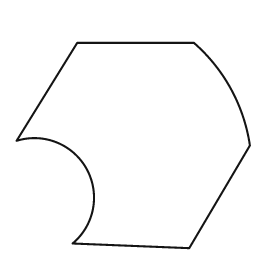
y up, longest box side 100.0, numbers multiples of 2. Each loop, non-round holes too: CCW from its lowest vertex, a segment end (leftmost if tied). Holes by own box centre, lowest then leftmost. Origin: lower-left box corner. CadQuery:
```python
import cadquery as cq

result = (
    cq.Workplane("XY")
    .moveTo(74.0, 0.0)
    .lineTo(100.0, 44.0)
    .threePointArc((92.0, 68.0), (76.0, 88.0))
    .lineTo(26.0, 88.0)
    .lineTo(0.0, 46.0)
    .threePointArc((30.0, 34.0), (24.0, 2.0))
    .close()
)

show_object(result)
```